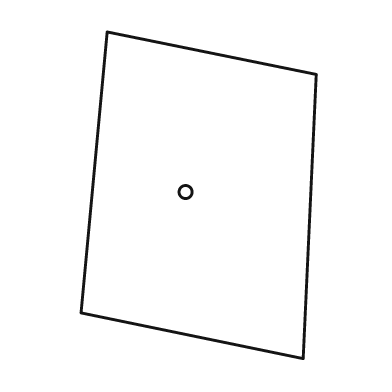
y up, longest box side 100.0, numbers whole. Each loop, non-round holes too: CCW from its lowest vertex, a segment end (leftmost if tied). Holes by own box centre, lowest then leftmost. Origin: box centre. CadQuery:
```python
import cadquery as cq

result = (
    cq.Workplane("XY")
    .moveTo(32.0, -50.0)
    .lineTo(36.0, 37.0)
    .lineTo(-28.0, 50.0)
    .lineTo(-36.0, -36.0)
    .close()
    .moveTo(-4.0, 1.0)
    .circle(2.0)
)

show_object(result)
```